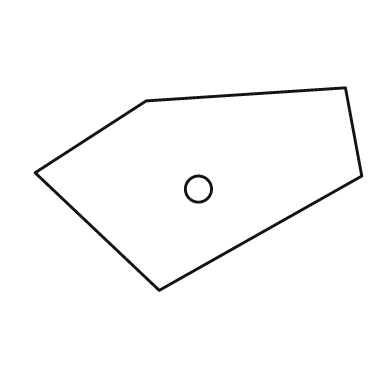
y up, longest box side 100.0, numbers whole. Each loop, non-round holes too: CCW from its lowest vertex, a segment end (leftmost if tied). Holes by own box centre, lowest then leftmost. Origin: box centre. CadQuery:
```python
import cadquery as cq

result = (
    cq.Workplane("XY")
    .moveTo(-12.0, -31.0)
    .lineTo(50.0, 4.0)
    .lineTo(45.0, 31.0)
    .lineTo(-16.0, 27.0)
    .lineTo(-50.0, 5.0)
    .close()
    .moveTo(0.0, 0.0)
    .circle(4.0)
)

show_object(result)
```